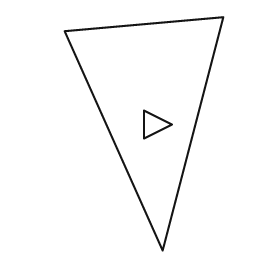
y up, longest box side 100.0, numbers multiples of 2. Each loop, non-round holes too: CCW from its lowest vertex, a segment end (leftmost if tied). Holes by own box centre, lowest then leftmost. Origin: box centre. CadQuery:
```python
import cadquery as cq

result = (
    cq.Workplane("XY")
    .moveTo(8.0, -50.0)
    .lineTo(34.0, 50.0)
    .lineTo(-34.0, 44.0)
    .close()
    .moveTo(0.0, -2.0)
    .lineTo(12.0, 4.0)
    .lineTo(0.0, 10.0)
    .close()
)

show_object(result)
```